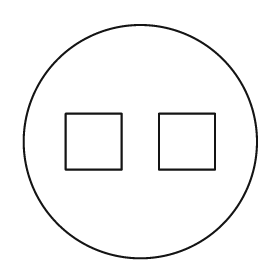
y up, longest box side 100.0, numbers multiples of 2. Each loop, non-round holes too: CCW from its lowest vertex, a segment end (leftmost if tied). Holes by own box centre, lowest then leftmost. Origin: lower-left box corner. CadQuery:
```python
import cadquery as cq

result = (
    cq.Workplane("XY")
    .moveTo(50.0, 50.0)
    .circle(50.0)
    .moveTo(18.0, 38.0)
    .lineTo(42.0, 38.0)
    .lineTo(42.0, 62.0)
    .lineTo(18.0, 62.0)
    .close()
    .moveTo(58.0, 38.0)
    .lineTo(82.0, 38.0)
    .lineTo(82.0, 62.0)
    .lineTo(58.0, 62.0)
    .close()
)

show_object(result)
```